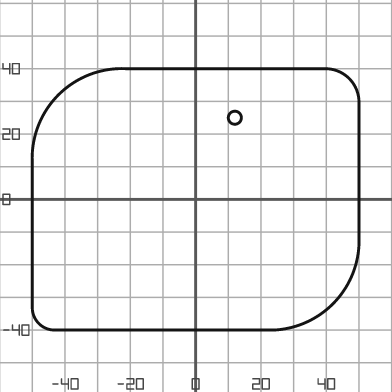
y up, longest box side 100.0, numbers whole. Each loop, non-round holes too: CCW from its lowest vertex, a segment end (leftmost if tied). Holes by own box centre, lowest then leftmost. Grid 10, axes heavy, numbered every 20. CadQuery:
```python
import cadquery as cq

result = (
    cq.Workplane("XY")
    .moveTo(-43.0, -40.0)
    .lineTo(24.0, -40.0)
    .threePointArc((42.0, -32.0), (50.0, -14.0))
    .lineTo(50.0, 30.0)
    .threePointArc((47.0, 37.0), (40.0, 40.0))
    .lineTo(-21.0, 40.0)
    .threePointArc((-42.0, 32.0), (-50.0, 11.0))
    .lineTo(-50.0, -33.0)
    .threePointArc((-48.0, -38.0), (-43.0, -40.0))
    .close()
    .moveTo(12.0, 25.0)
    .circle(2.0)
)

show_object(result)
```